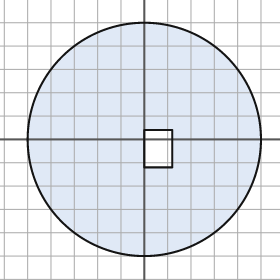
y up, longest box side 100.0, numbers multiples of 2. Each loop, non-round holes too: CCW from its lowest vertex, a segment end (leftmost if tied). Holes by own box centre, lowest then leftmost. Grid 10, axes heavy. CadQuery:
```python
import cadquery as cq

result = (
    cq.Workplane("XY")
    .moveTo(0.0, 0.0)
    .circle(50.0)
    .moveTo(0.0, -12.0)
    .lineTo(12.0, -12.0)
    .lineTo(12.0, 4.0)
    .lineTo(0.0, 4.0)
    .close()
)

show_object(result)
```